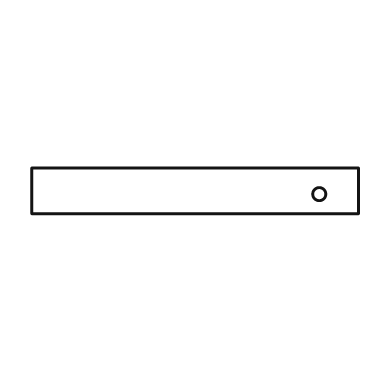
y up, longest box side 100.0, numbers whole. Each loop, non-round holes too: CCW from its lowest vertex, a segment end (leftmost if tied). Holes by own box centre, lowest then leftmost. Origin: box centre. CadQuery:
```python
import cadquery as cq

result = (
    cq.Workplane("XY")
    .moveTo(-50.0, -7.0)
    .lineTo(50.0, -7.0)
    .lineTo(50.0, 7.0)
    .lineTo(-50.0, 7.0)
    .close()
    .moveTo(38.0, -1.0)
    .circle(2.0)
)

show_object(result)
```